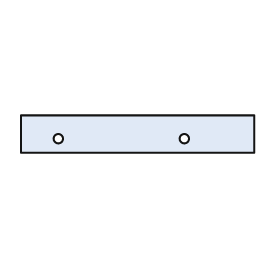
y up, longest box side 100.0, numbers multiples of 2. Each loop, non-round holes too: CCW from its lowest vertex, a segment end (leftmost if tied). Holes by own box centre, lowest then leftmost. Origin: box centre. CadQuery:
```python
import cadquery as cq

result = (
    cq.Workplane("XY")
    .moveTo(-50.0, -8.0)
    .lineTo(50.0, -8.0)
    .lineTo(50.0, 8.0)
    .lineTo(-50.0, 8.0)
    .close()
    .moveTo(-34.0, -2.0)
    .circle(2.0)
    .moveTo(20.0, -2.0)
    .circle(2.0)
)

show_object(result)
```